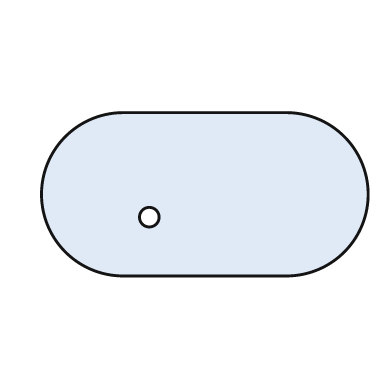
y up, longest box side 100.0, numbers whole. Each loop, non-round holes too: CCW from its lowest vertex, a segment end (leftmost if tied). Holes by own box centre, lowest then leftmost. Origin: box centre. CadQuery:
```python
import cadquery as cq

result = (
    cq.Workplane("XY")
    .moveTo(-25.0, -25.0)
    .lineTo(25.0, -25.0)
    .threePointArc((50.0, 0.0), (25.0, 25.0))
    .lineTo(-25.0, 25.0)
    .threePointArc((-50.0, 0.0), (-25.0, -25.0))
    .close()
    .moveTo(-17.0, -7.0)
    .circle(3.0)
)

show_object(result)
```